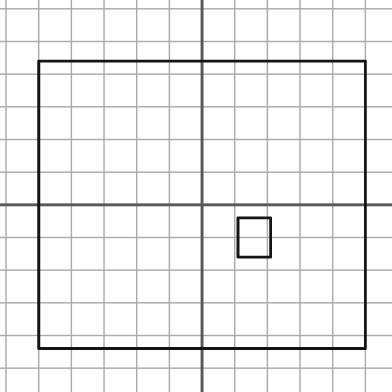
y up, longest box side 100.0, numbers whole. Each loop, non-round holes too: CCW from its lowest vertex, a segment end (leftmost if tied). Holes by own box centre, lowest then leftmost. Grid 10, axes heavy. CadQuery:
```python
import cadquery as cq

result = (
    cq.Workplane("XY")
    .moveTo(-50.0, -44.0)
    .lineTo(50.0, -44.0)
    .lineTo(50.0, 44.0)
    .lineTo(-50.0, 44.0)
    .close()
    .moveTo(11.0, -16.0)
    .lineTo(21.0, -16.0)
    .lineTo(21.0, -4.0)
    .lineTo(11.0, -4.0)
    .close()
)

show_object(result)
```